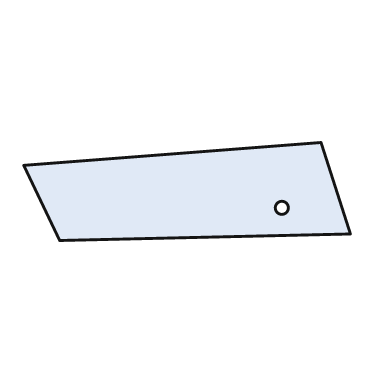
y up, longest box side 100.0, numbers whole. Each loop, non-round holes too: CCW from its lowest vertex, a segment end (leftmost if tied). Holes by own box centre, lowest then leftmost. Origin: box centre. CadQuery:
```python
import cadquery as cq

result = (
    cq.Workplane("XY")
    .moveTo(-39.0, -15.0)
    .lineTo(50.0, -13.0)
    .lineTo(41.0, 15.0)
    .lineTo(-50.0, 8.0)
    .close()
    .moveTo(29.0, -5.0)
    .circle(2.0)
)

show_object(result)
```